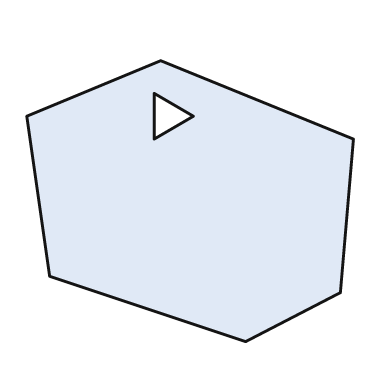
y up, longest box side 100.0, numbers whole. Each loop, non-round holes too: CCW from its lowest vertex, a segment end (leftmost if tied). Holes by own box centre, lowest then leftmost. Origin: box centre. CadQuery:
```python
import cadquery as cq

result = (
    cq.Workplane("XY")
    .moveTo(17.0, -43.0)
    .lineTo(46.0, -28.0)
    .lineTo(50.0, 19.0)
    .lineTo(-9.0, 43.0)
    .lineTo(-50.0, 26.0)
    .lineTo(-43.0, -23.0)
    .close()
    .moveTo(-11.0, 19.0)
    .lineTo(1.0, 26.0)
    .lineTo(-11.0, 33.0)
    .close()
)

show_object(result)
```